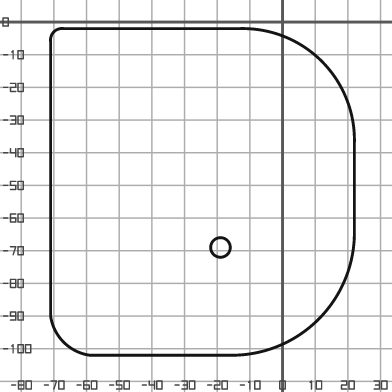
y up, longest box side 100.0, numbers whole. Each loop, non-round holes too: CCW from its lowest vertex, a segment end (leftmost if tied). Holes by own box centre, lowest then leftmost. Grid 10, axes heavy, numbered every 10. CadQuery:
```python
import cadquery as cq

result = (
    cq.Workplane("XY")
    .moveTo(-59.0, -102.0)
    .lineTo(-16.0, -102.0)
    .threePointArc((11.0, -91.0), (22.0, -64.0))
    .lineTo(22.0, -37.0)
    .threePointArc((12.0, -12.0), (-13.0, -2.0))
    .lineTo(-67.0, -2.0)
    .threePointArc((-70.0, -3.0), (-71.0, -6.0))
    .lineTo(-71.0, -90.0)
    .threePointArc((-67.0, -98.0), (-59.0, -102.0))
    .close()
    .moveTo(-19.0, -69.0)
    .circle(3.0)
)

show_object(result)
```